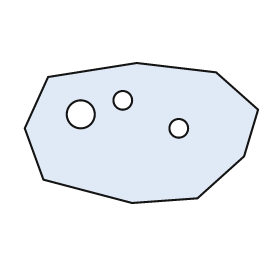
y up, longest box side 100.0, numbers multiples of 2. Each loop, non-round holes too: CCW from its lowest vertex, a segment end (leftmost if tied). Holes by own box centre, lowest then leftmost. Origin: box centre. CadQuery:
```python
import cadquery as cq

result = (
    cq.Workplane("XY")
    .moveTo(-4.0, -30.0)
    .lineTo(24.0, -28.0)
    .lineTo(44.0, -10.0)
    .lineTo(50.0, 10.0)
    .lineTo(32.0, 26.0)
    .lineTo(-2.0, 30.0)
    .lineTo(-40.0, 24.0)
    .lineTo(-50.0, 2.0)
    .lineTo(-42.0, -20.0)
    .close()
    .moveTo(16.0, 2.0)
    .circle(4.0)
    .moveTo(-26.0, 8.0)
    .circle(6.0)
    .moveTo(-8.0, 14.0)
    .circle(4.0)
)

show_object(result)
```